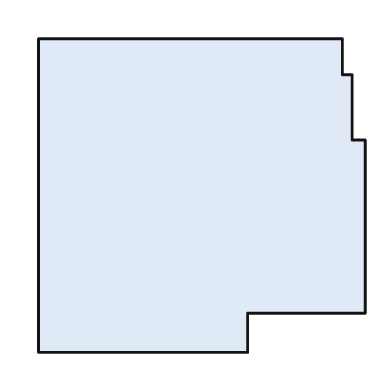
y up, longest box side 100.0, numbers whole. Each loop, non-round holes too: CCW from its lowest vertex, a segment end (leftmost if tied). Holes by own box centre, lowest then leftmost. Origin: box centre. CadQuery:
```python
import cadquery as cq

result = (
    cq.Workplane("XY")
    .moveTo(-50.0, -48.0)
    .lineTo(14.0, -48.0)
    .lineTo(14.0, -36.0)
    .lineTo(50.0, -36.0)
    .lineTo(50.0, 17.0)
    .lineTo(46.0, 17.0)
    .lineTo(46.0, 37.0)
    .lineTo(43.0, 37.0)
    .lineTo(43.0, 48.0)
    .lineTo(-50.0, 48.0)
    .close()
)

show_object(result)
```